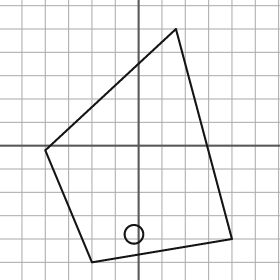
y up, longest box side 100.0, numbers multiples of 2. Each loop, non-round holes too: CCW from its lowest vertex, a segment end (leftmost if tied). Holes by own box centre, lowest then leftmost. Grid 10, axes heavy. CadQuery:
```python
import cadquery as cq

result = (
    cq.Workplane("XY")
    .moveTo(-20.0, -50.0)
    .lineTo(40.0, -40.0)
    .lineTo(16.0, 50.0)
    .lineTo(-40.0, -2.0)
    .close()
    .moveTo(-2.0, -38.0)
    .circle(4.0)
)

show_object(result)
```